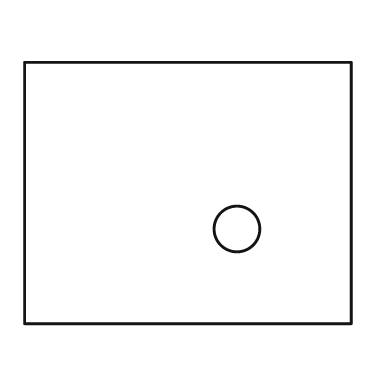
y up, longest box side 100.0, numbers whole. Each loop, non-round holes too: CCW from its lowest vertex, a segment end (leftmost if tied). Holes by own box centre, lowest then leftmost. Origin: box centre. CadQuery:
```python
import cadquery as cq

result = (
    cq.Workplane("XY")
    .moveTo(-50.0, -40.0)
    .lineTo(50.0, -40.0)
    .lineTo(50.0, 40.0)
    .lineTo(-50.0, 40.0)
    .close()
    .moveTo(15.0, -11.0)
    .circle(7.0)
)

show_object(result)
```